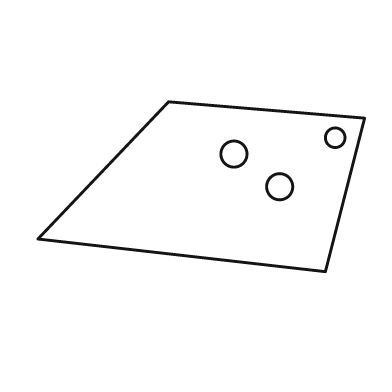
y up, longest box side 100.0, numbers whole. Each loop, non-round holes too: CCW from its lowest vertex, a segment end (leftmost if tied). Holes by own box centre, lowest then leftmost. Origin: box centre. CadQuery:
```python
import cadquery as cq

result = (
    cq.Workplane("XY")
    .moveTo(38.0, -26.0)
    .lineTo(50.0, 21.0)
    .lineTo(-10.0, 26.0)
    .lineTo(-50.0, -16.0)
    .close()
    .moveTo(24.0, 0.0)
    .circle(4.0)
    .moveTo(10.0, 10.0)
    .circle(4.0)
    .moveTo(41.0, 15.0)
    .circle(3.0)
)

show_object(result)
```